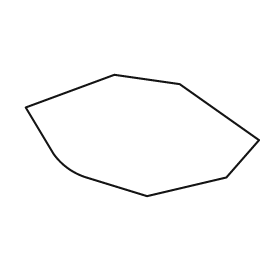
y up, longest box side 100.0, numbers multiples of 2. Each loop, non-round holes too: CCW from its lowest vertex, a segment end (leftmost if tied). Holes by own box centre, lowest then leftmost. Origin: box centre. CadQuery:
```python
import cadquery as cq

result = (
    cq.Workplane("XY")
    .moveTo(2.0, -26.0)
    .lineTo(36.0, -18.0)
    .lineTo(50.0, -2.0)
    .lineTo(16.0, 22.0)
    .lineTo(-12.0, 26.0)
    .lineTo(-50.0, 12.0)
    .lineTo(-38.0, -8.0)
    .threePointArc((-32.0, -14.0), (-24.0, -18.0))
    .close()
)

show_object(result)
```